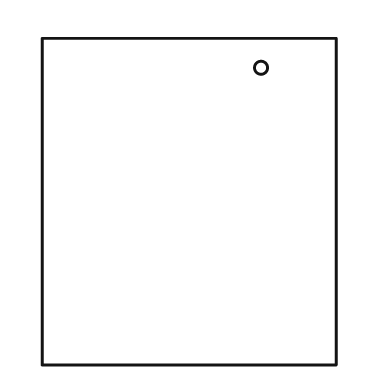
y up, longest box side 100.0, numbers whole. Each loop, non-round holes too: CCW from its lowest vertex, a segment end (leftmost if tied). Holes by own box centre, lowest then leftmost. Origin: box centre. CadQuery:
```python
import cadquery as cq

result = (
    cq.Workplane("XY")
    .moveTo(-45.0, -50.0)
    .lineTo(45.0, -50.0)
    .lineTo(45.0, 50.0)
    .lineTo(-45.0, 50.0)
    .close()
    .moveTo(22.0, 41.0)
    .circle(2.0)
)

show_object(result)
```